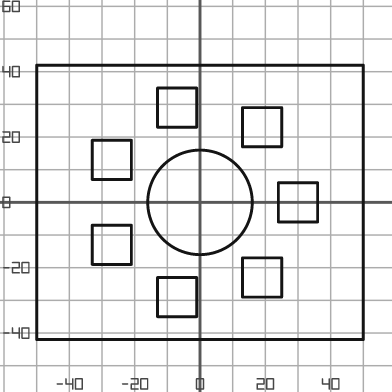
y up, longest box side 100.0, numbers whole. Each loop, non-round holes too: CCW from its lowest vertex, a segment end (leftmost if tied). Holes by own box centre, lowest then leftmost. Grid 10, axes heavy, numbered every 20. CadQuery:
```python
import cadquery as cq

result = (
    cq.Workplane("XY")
    .moveTo(-50.0, -42.0)
    .lineTo(50.0, -42.0)
    .lineTo(50.0, 42.0)
    .lineTo(-50.0, 42.0)
    .close()
    .moveTo(-13.0, -35.0)
    .lineTo(-1.0, -35.0)
    .lineTo(-1.0, -23.0)
    .lineTo(-13.0, -23.0)
    .close()
    .moveTo(13.0, -29.0)
    .lineTo(25.0, -29.0)
    .lineTo(25.0, -17.0)
    .lineTo(13.0, -17.0)
    .close()
    .moveTo(-33.0, -19.0)
    .lineTo(-21.0, -19.0)
    .lineTo(-21.0, -7.0)
    .lineTo(-33.0, -7.0)
    .close()
    .moveTo(0.0, 0.0)
    .circle(16.0)
    .moveTo(24.0, -6.0)
    .lineTo(36.0, -6.0)
    .lineTo(36.0, 6.0)
    .lineTo(24.0, 6.0)
    .close()
    .moveTo(-33.0, 7.0)
    .lineTo(-21.0, 7.0)
    .lineTo(-21.0, 19.0)
    .lineTo(-33.0, 19.0)
    .close()
    .moveTo(13.0, 17.0)
    .lineTo(25.0, 17.0)
    .lineTo(25.0, 29.0)
    .lineTo(13.0, 29.0)
    .close()
    .moveTo(-13.0, 23.0)
    .lineTo(-1.0, 23.0)
    .lineTo(-1.0, 35.0)
    .lineTo(-13.0, 35.0)
    .close()
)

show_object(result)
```